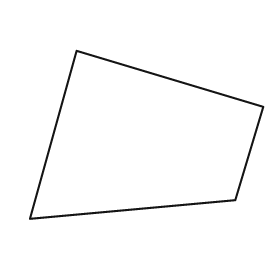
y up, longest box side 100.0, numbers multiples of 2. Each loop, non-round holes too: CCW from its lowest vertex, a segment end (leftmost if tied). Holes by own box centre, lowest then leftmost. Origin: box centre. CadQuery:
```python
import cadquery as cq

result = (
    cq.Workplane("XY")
    .moveTo(-50.0, -36.0)
    .lineTo(38.0, -28.0)
    .lineTo(50.0, 12.0)
    .lineTo(-30.0, 36.0)
    .close()
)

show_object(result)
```